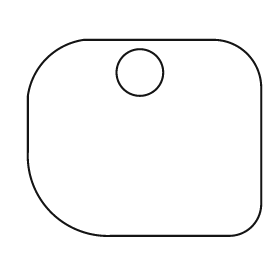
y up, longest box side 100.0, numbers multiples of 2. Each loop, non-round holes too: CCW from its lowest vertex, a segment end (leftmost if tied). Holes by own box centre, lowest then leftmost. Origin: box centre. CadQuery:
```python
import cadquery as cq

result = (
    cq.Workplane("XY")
    .moveTo(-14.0, -42.0)
    .lineTo(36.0, -42.0)
    .threePointArc((46.0, -38.0), (50.0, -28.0))
    .lineTo(50.0, 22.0)
    .threePointArc((44.0, 36.0), (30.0, 42.0))
    .lineTo(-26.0, 42.0)
    .threePointArc((-42.0, 34.0), (-50.0, 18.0))
    .lineTo(-50.0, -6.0)
    .threePointArc((-40.0, -32.0), (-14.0, -42.0))
    .close()
    .moveTo(-2.0, 28.0)
    .circle(10.0)
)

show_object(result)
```